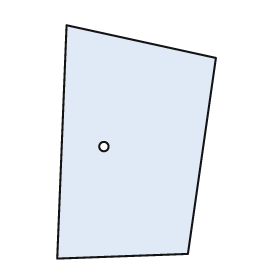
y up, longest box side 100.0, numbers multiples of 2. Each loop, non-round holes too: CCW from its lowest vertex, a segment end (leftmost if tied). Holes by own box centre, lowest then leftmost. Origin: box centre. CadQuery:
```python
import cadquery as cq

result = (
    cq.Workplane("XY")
    .moveTo(-34.0, -50.0)
    .lineTo(22.0, -48.0)
    .lineTo(34.0, 36.0)
    .lineTo(-30.0, 50.0)
    .close()
    .moveTo(-14.0, -2.0)
    .circle(2.0)
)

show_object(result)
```